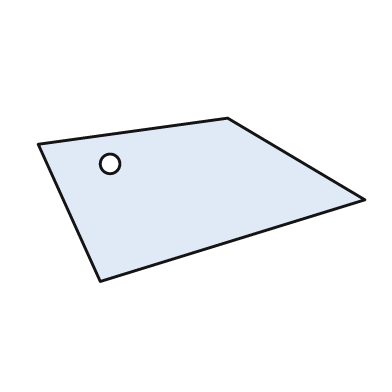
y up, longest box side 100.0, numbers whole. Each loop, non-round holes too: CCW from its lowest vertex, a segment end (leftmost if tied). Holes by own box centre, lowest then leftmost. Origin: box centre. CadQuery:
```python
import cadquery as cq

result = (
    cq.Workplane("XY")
    .moveTo(-31.0, -25.0)
    .lineTo(50.0, 0.0)
    .lineTo(8.0, 25.0)
    .lineTo(-50.0, 17.0)
    .close()
    .moveTo(-28.0, 11.0)
    .circle(3.0)
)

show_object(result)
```